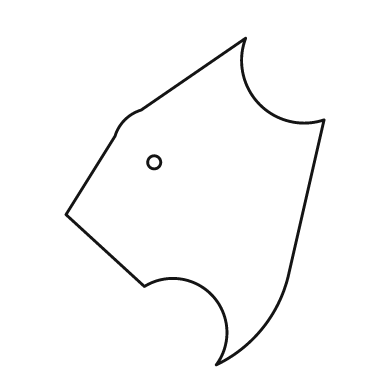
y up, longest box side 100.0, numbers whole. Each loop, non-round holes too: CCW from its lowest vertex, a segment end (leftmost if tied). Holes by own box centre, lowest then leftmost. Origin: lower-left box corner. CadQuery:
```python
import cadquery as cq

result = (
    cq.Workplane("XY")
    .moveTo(46.0, 0.0)
    .threePointArc((60.0, 11.0), (68.0, 27.0))
    .lineTo(79.0, 75.0)
    .threePointArc((59.0, 80.0), (55.0, 100.0))
    .lineTo(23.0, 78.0)
    .threePointArc((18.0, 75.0), (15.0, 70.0))
    .lineTo(0.0, 46.0)
    .lineTo(24.0, 24.0)
    .threePointArc((45.0, 21.0), (46.0, 0.0))
    .close()
    .moveTo(27.0, 62.0)
    .circle(2.0)
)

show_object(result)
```